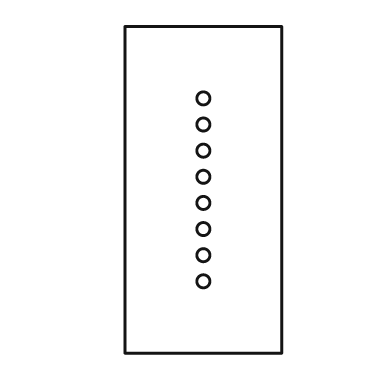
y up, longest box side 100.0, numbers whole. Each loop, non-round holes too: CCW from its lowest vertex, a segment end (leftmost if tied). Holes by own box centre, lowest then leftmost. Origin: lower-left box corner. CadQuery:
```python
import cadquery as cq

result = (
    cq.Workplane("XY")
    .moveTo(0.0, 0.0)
    .lineTo(48.0, 0.0)
    .lineTo(48.0, 100.0)
    .lineTo(0.0, 100.0)
    .close()
    .moveTo(24.0, 22.0)
    .circle(2.0)
    .moveTo(24.0, 30.0)
    .circle(2.0)
    .moveTo(24.0, 38.0)
    .circle(2.0)
    .moveTo(24.0, 46.0)
    .circle(2.0)
    .moveTo(24.0, 54.0)
    .circle(2.0)
    .moveTo(24.0, 62.0)
    .circle(2.0)
    .moveTo(24.0, 70.0)
    .circle(2.0)
    .moveTo(24.0, 78.0)
    .circle(2.0)
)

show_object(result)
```